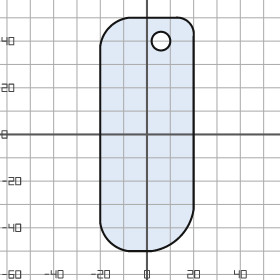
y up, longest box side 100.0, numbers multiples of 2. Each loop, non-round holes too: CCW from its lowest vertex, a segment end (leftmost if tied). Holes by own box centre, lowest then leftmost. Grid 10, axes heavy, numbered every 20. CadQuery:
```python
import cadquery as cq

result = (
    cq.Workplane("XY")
    .moveTo(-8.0, -50.0)
    .lineTo(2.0, -50.0)
    .threePointArc((14.0, -44.0), (20.0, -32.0))
    .lineTo(20.0, 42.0)
    .threePointArc((18.0, 48.0), (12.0, 50.0))
    .lineTo(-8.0, 50.0)
    .threePointArc((-16.0, 46.0), (-20.0, 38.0))
    .lineTo(-20.0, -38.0)
    .threePointArc((-16.0, -46.0), (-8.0, -50.0))
    .close()
    .moveTo(6.0, 40.0)
    .circle(4.0)
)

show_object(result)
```